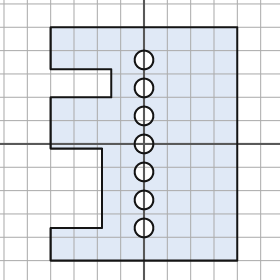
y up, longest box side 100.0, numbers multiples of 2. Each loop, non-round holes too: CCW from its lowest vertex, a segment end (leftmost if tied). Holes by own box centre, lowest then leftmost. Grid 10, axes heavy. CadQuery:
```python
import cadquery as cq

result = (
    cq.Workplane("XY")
    .moveTo(-40.0, -50.0)
    .lineTo(40.0, -50.0)
    .lineTo(40.0, 50.0)
    .lineTo(-40.0, 50.0)
    .lineTo(-40.0, 32.0)
    .lineTo(-14.0, 32.0)
    .lineTo(-14.0, 20.0)
    .lineTo(-40.0, 20.0)
    .lineTo(-40.0, -2.0)
    .lineTo(-18.0, -2.0)
    .lineTo(-18.0, -36.0)
    .lineTo(-40.0, -36.0)
    .close()
    .moveTo(0.0, -36.0)
    .circle(4.0)
    .moveTo(0.0, -24.0)
    .circle(4.0)
    .moveTo(0.0, -12.0)
    .circle(4.0)
    .moveTo(0.0, 0.0)
    .circle(4.0)
    .moveTo(0.0, 12.0)
    .circle(4.0)
    .moveTo(0.0, 24.0)
    .circle(4.0)
    .moveTo(0.0, 36.0)
    .circle(4.0)
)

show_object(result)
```